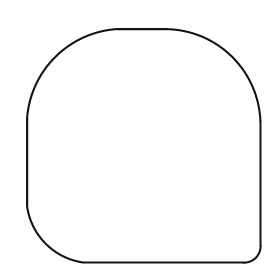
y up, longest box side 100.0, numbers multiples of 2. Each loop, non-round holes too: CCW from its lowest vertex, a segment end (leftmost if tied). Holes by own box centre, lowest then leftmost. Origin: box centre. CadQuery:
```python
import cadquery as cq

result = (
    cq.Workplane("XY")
    .moveTo(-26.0, -50.0)
    .lineTo(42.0, -50.0)
    .threePointArc((48.0, -48.0), (50.0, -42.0))
    .lineTo(50.0, 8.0)
    .threePointArc((38.0, 38.0), (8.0, 50.0))
    .lineTo(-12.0, 50.0)
    .threePointArc((-38.0, 38.0), (-50.0, 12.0))
    .lineTo(-50.0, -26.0)
    .threePointArc((-42.0, -42.0), (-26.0, -50.0))
    .close()
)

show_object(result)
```